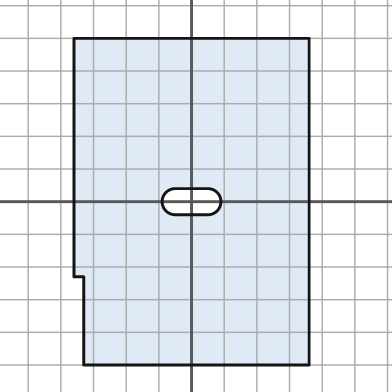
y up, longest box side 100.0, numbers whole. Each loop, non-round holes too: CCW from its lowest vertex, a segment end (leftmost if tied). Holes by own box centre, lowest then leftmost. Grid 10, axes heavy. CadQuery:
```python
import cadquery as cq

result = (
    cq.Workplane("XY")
    .moveTo(-33.0, -50.0)
    .lineTo(36.0, -50.0)
    .lineTo(36.0, 50.0)
    .lineTo(-36.0, 50.0)
    .lineTo(-36.0, -23.0)
    .lineTo(-33.0, -23.0)
    .close()
    .moveTo(-5.0, -4.0)
    .lineTo(5.0, -4.0)
    .threePointArc((9.0, 0.0), (5.0, 4.0))
    .lineTo(-5.0, 4.0)
    .threePointArc((-9.0, 0.0), (-5.0, -4.0))
    .close()
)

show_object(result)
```